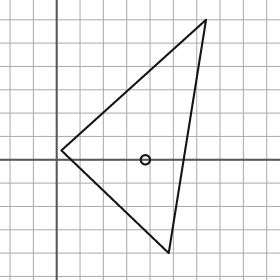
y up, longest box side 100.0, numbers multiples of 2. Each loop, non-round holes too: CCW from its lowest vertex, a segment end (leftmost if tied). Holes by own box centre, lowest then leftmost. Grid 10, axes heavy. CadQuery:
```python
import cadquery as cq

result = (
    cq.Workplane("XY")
    .moveTo(48.0, -40.0)
    .lineTo(64.0, 60.0)
    .lineTo(2.0, 4.0)
    .close()
    .moveTo(38.0, 0.0)
    .circle(2.0)
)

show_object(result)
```